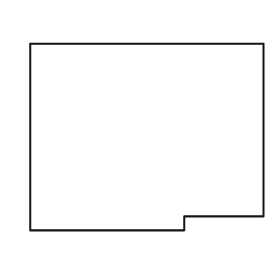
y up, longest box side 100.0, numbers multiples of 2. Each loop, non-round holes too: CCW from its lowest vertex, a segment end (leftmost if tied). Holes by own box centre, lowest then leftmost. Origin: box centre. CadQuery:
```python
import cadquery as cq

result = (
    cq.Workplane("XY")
    .moveTo(-50.0, -40.0)
    .lineTo(16.0, -40.0)
    .lineTo(16.0, -34.0)
    .lineTo(50.0, -34.0)
    .lineTo(50.0, 40.0)
    .lineTo(-50.0, 40.0)
    .close()
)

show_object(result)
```